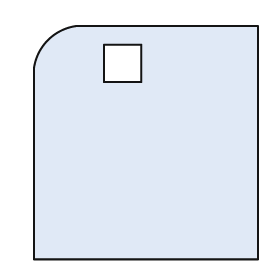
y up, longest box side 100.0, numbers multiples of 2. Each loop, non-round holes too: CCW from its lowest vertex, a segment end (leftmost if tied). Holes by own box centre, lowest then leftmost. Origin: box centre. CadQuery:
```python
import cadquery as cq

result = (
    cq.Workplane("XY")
    .moveTo(-48.0, -50.0)
    .lineTo(48.0, -50.0)
    .lineTo(48.0, 50.0)
    .lineTo(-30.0, 50.0)
    .threePointArc((-42.0, 44.0), (-48.0, 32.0))
    .close()
    .moveTo(-18.0, 26.0)
    .lineTo(-2.0, 26.0)
    .lineTo(-2.0, 42.0)
    .lineTo(-18.0, 42.0)
    .close()
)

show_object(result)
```